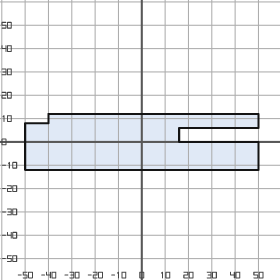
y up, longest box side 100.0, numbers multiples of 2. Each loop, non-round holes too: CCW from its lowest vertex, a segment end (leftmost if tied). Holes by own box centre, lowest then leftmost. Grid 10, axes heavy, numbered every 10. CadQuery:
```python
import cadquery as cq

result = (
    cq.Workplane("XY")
    .moveTo(-50.0, -12.0)
    .lineTo(50.0, -12.0)
    .lineTo(50.0, 0.0)
    .lineTo(16.0, 0.0)
    .lineTo(16.0, 6.0)
    .lineTo(50.0, 6.0)
    .lineTo(50.0, 12.0)
    .lineTo(-40.0, 12.0)
    .lineTo(-40.0, 8.0)
    .lineTo(-50.0, 8.0)
    .close()
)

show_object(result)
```